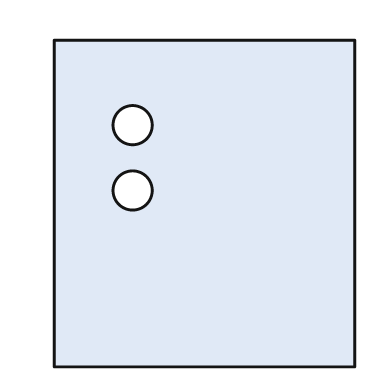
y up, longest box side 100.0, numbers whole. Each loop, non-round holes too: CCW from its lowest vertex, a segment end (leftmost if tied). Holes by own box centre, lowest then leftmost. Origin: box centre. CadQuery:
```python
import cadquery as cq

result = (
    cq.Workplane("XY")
    .moveTo(-46.0, -50.0)
    .lineTo(46.0, -50.0)
    .lineTo(46.0, 50.0)
    .lineTo(-46.0, 50.0)
    .close()
    .moveTo(-22.0, 4.0)
    .circle(6.0)
    .moveTo(-22.0, 24.0)
    .circle(6.0)
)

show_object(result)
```